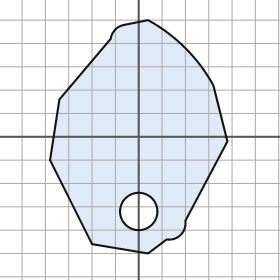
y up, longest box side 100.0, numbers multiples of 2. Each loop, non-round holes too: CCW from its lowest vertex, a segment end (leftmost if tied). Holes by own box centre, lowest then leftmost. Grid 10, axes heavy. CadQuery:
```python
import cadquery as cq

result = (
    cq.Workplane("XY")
    .moveTo(4.0, -50.0)
    .lineTo(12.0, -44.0)
    .threePointArc((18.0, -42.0), (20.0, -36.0))
    .lineTo(38.0, -2.0)
    .lineTo(32.0, 22.0)
    .threePointArc((20.0, 38.0), (4.0, 50.0))
    .lineTo(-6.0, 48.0)
    .threePointArc((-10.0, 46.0), (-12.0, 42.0))
    .lineTo(-34.0, 16.0)
    .lineTo(-38.0, -10.0)
    .lineTo(-20.0, -46.0)
    .close()
    .moveTo(0.0, -32.0)
    .circle(8.0)
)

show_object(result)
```